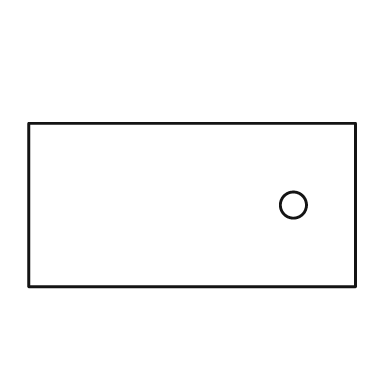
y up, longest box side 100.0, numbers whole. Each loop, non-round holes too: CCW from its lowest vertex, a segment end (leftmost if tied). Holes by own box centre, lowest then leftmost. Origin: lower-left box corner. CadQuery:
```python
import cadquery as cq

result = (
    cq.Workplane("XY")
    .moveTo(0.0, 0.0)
    .lineTo(100.0, 0.0)
    .lineTo(100.0, 50.0)
    .lineTo(0.0, 50.0)
    .close()
    .moveTo(81.0, 25.0)
    .circle(4.0)
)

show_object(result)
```